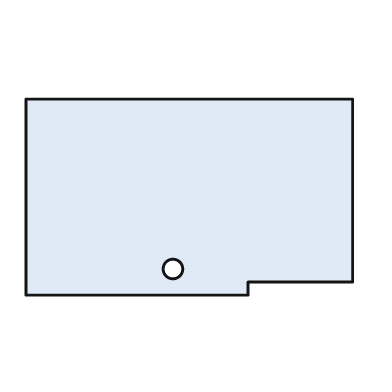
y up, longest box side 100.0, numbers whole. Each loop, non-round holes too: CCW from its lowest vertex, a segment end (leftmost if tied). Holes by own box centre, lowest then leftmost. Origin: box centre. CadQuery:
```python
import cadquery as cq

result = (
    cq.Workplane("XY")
    .moveTo(-50.0, -30.0)
    .lineTo(18.0, -30.0)
    .lineTo(18.0, -26.0)
    .lineTo(50.0, -26.0)
    .lineTo(50.0, 30.0)
    .lineTo(-50.0, 30.0)
    .close()
    .moveTo(-5.0, -22.0)
    .circle(3.0)
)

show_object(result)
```